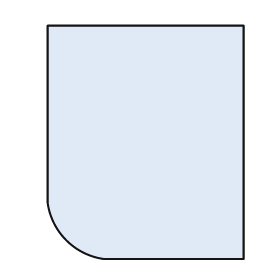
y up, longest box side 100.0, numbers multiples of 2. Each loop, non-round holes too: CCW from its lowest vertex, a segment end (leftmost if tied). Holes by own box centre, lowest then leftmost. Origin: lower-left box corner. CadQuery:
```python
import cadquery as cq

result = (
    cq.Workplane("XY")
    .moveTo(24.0, 0.0)
    .lineTo(84.0, 0.0)
    .lineTo(84.0, 100.0)
    .lineTo(0.0, 100.0)
    .lineTo(0.0, 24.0)
    .threePointArc((8.0, 8.0), (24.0, 0.0))
    .close()
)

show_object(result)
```